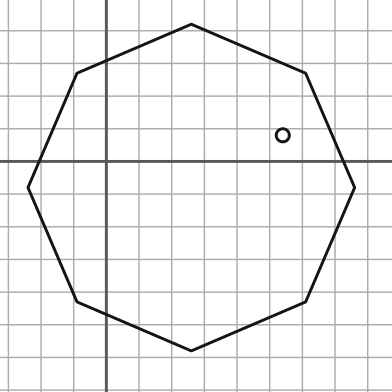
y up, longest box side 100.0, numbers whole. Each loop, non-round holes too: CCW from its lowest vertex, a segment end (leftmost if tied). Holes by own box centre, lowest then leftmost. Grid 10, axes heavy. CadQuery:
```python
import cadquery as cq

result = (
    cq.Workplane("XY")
    .moveTo(26.0, -58.0)
    .lineTo(61.0, -43.0)
    .lineTo(76.0, -8.0)
    .lineTo(61.0, 27.0)
    .lineTo(26.0, 42.0)
    .lineTo(-9.0, 27.0)
    .lineTo(-24.0, -8.0)
    .lineTo(-9.0, -43.0)
    .close()
    .moveTo(54.0, 8.0)
    .circle(2.0)
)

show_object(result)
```